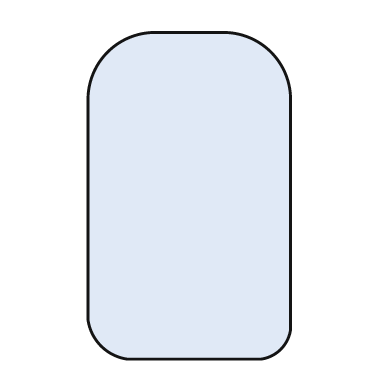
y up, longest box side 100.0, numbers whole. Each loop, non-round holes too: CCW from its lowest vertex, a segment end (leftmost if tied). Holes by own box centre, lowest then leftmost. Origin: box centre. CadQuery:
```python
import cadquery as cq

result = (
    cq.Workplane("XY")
    .moveTo(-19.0, -50.0)
    .lineTo(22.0, -50.0)
    .threePointArc((28.0, -47.0), (31.0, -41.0))
    .lineTo(31.0, 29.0)
    .threePointArc((25.0, 44.0), (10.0, 50.0))
    .lineTo(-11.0, 50.0)
    .threePointArc((-25.0, 44.0), (-31.0, 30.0))
    .lineTo(-31.0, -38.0)
    .threePointArc((-27.0, -46.0), (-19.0, -50.0))
    .close()
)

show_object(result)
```